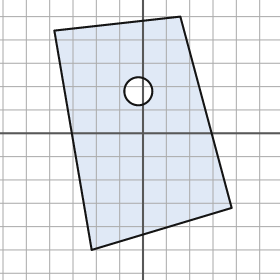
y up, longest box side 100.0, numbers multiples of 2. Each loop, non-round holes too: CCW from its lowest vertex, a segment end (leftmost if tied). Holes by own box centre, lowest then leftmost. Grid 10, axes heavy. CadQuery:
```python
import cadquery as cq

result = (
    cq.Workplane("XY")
    .moveTo(-22.0, -50.0)
    .lineTo(38.0, -32.0)
    .lineTo(16.0, 50.0)
    .lineTo(-38.0, 44.0)
    .close()
    .moveTo(-2.0, 18.0)
    .circle(6.0)
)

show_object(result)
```